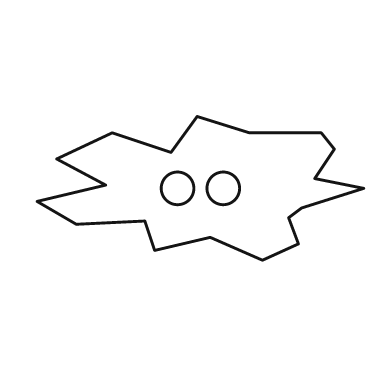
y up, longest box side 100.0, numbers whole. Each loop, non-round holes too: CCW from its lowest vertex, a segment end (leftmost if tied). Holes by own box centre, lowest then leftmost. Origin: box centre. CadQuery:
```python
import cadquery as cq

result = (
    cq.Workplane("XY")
    .moveTo(19.0, -22.0)
    .lineTo(30.0, -17.0)
    .lineTo(27.0, -9.0)
    .lineTo(31.0, -6.0)
    .lineTo(50.0, 0.0)
    .lineTo(35.0, 3.0)
    .lineTo(41.0, 12.0)
    .lineTo(37.0, 17.0)
    .lineTo(15.0, 17.0)
    .lineTo(-1.0, 22.0)
    .lineTo(-9.0, 11.0)
    .lineTo(-27.0, 17.0)
    .lineTo(-44.0, 9.0)
    .lineTo(-29.0, 1.0)
    .lineTo(-50.0, -4.0)
    .lineTo(-38.0, -11.0)
    .lineTo(-17.0, -10.0)
    .lineTo(-14.0, -19.0)
    .lineTo(3.0, -15.0)
    .close()
    .moveTo(-7.0, 0.0)
    .circle(5.0)
    .moveTo(7.0, 0.0)
    .circle(5.0)
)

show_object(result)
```